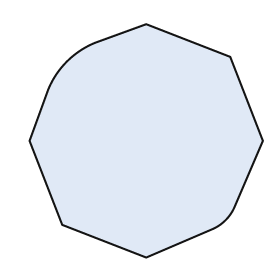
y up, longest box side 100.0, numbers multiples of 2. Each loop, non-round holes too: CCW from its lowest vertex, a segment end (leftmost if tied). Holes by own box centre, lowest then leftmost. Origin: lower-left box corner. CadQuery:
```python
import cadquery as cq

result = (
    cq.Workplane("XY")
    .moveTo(50.0, 0.0)
    .lineTo(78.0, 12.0)
    .threePointArc((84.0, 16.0), (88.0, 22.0))
    .lineTo(100.0, 50.0)
    .lineTo(86.0, 86.0)
    .lineTo(50.0, 100.0)
    .lineTo(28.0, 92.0)
    .threePointArc((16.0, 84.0), (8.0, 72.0))
    .lineTo(0.0, 50.0)
    .lineTo(14.0, 14.0)
    .close()
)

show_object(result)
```